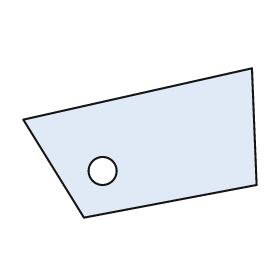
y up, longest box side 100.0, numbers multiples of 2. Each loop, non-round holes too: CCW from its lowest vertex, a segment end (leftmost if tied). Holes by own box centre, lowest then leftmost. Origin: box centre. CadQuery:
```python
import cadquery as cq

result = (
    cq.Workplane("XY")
    .moveTo(-24.0, -32.0)
    .lineTo(50.0, -18.0)
    .lineTo(48.0, 32.0)
    .lineTo(-50.0, 10.0)
    .close()
    .moveTo(-16.0, -12.0)
    .circle(6.0)
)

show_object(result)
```